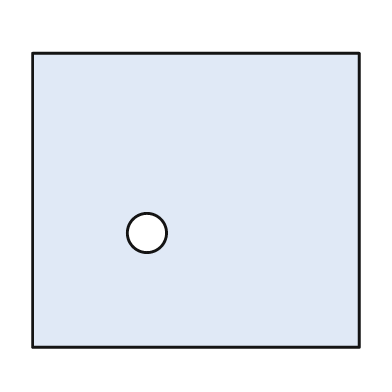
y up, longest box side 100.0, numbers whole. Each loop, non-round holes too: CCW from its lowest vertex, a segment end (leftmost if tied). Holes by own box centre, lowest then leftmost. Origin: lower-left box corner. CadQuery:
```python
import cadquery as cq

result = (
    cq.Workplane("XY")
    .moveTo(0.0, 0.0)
    .lineTo(100.0, 0.0)
    .lineTo(100.0, 90.0)
    .lineTo(0.0, 90.0)
    .close()
    .moveTo(35.0, 35.0)
    .circle(6.0)
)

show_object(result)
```